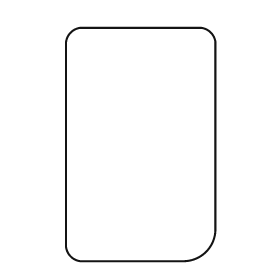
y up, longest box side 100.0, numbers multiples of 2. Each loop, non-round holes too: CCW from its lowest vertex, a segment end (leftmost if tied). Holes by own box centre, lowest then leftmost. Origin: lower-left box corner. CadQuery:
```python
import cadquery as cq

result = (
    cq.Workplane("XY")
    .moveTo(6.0, 0.0)
    .lineTo(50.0, 0.0)
    .threePointArc((60.0, 4.0), (64.0, 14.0))
    .lineTo(64.0, 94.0)
    .threePointArc((62.0, 98.0), (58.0, 100.0))
    .lineTo(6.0, 100.0)
    .threePointArc((2.0, 98.0), (0.0, 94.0))
    .lineTo(0.0, 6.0)
    .threePointArc((2.0, 2.0), (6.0, 0.0))
    .close()
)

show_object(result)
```